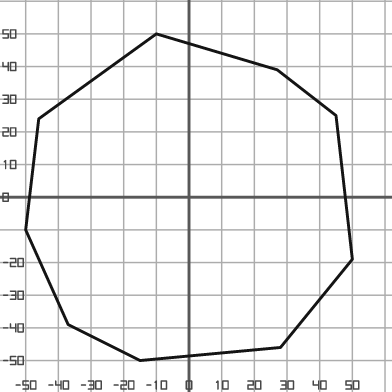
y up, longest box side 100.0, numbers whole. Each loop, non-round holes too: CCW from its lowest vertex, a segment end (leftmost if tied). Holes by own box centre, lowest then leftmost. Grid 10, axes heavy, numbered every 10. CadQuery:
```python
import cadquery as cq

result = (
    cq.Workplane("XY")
    .moveTo(-15.0, -50.0)
    .lineTo(28.0, -46.0)
    .lineTo(50.0, -19.0)
    .lineTo(45.0, 25.0)
    .lineTo(27.0, 39.0)
    .lineTo(-10.0, 50.0)
    .lineTo(-46.0, 24.0)
    .lineTo(-50.0, -10.0)
    .lineTo(-37.0, -39.0)
    .close()
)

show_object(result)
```